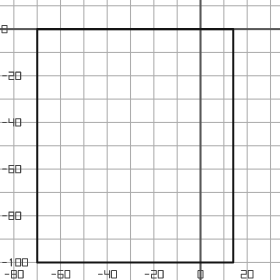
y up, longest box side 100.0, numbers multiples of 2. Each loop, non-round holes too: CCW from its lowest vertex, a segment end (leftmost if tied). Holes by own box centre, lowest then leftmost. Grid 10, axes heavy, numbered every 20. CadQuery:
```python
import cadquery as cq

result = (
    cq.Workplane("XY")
    .moveTo(-70.0, -100.0)
    .lineTo(14.0, -100.0)
    .lineTo(14.0, 0.0)
    .lineTo(-70.0, 0.0)
    .close()
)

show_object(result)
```